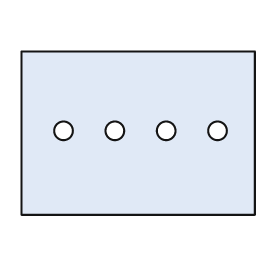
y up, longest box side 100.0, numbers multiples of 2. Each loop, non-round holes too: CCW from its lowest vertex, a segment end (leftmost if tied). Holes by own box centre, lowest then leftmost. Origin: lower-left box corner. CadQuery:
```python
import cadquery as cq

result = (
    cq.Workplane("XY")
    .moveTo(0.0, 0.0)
    .lineTo(100.0, 0.0)
    .lineTo(100.0, 70.0)
    .lineTo(0.0, 70.0)
    .close()
    .moveTo(18.0, 36.0)
    .circle(4.0)
    .moveTo(40.0, 36.0)
    .circle(4.0)
    .moveTo(62.0, 36.0)
    .circle(4.0)
    .moveTo(84.0, 36.0)
    .circle(4.0)
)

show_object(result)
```